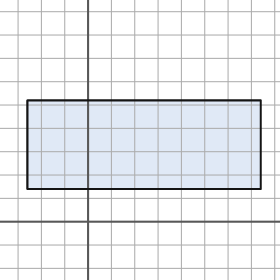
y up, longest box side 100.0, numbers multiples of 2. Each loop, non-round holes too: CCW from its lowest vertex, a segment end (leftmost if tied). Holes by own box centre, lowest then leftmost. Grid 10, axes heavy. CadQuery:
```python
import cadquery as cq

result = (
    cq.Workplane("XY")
    .moveTo(-26.0, 14.0)
    .lineTo(74.0, 14.0)
    .lineTo(74.0, 52.0)
    .lineTo(-26.0, 52.0)
    .close()
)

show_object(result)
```